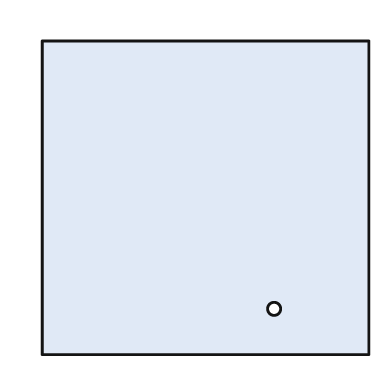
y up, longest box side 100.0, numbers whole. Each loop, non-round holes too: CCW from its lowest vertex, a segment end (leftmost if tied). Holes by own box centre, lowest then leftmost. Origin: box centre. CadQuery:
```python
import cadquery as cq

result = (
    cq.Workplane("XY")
    .moveTo(-50.0, -48.0)
    .lineTo(50.0, -48.0)
    .lineTo(50.0, 48.0)
    .lineTo(-50.0, 48.0)
    .close()
    .moveTo(21.0, -34.0)
    .circle(2.0)
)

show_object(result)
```